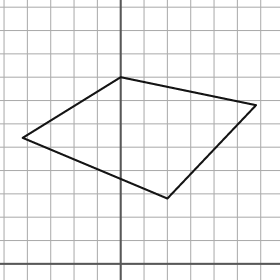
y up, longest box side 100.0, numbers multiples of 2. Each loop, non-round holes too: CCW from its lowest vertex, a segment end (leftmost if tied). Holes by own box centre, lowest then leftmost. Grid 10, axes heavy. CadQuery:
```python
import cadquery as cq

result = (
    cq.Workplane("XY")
    .moveTo(20.0, 28.0)
    .lineTo(58.0, 68.0)
    .lineTo(0.0, 80.0)
    .lineTo(-42.0, 54.0)
    .close()
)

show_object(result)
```